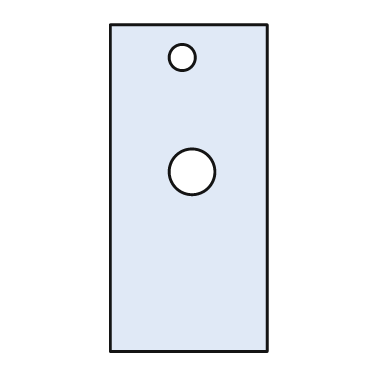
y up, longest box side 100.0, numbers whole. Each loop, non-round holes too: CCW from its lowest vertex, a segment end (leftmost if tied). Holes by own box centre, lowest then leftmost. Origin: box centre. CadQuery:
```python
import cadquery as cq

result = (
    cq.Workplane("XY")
    .moveTo(-24.0, -50.0)
    .lineTo(24.0, -50.0)
    .lineTo(24.0, 50.0)
    .lineTo(-24.0, 50.0)
    .close()
    .moveTo(1.0, 5.0)
    .circle(7.0)
    .moveTo(-2.0, 40.0)
    .circle(4.0)
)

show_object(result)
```